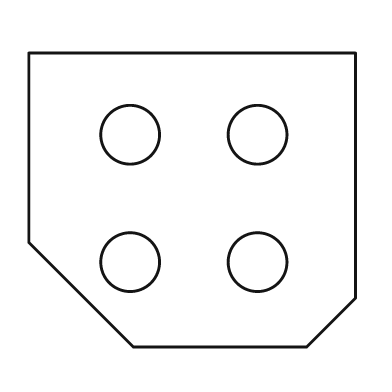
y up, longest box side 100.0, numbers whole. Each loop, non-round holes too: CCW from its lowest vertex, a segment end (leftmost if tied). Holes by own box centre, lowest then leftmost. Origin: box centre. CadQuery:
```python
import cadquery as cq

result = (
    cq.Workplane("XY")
    .moveTo(-18.0, -45.0)
    .lineTo(35.0, -45.0)
    .lineTo(50.0, -30.0)
    .lineTo(50.0, 45.0)
    .lineTo(-50.0, 45.0)
    .lineTo(-50.0, -13.0)
    .close()
    .moveTo(-19.0, -19.0)
    .circle(9.0)
    .moveTo(20.0, -19.0)
    .circle(9.0)
    .moveTo(-19.0, 20.0)
    .circle(9.0)
    .moveTo(20.0, 20.0)
    .circle(9.0)
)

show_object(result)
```